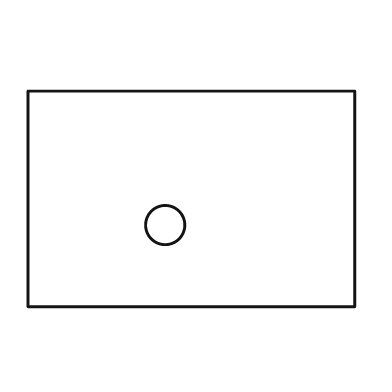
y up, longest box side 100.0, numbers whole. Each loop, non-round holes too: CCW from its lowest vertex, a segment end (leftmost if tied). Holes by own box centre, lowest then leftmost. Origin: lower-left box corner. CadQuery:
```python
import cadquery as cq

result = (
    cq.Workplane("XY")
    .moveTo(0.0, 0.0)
    .lineTo(100.0, 0.0)
    .lineTo(100.0, 66.0)
    .lineTo(0.0, 66.0)
    .close()
    .moveTo(42.0, 25.0)
    .circle(6.0)
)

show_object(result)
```